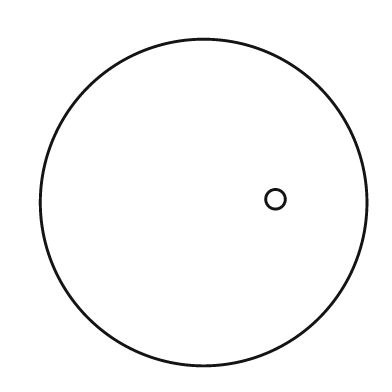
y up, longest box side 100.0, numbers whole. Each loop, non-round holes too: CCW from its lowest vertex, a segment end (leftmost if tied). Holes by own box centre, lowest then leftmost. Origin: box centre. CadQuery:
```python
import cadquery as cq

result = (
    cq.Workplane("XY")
    .moveTo(0.0, 0.0)
    .circle(50.0)
    .moveTo(22.0, 1.0)
    .circle(3.0)
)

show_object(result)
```